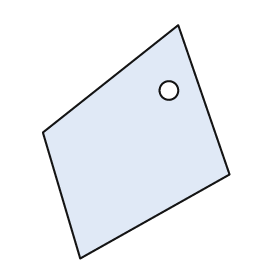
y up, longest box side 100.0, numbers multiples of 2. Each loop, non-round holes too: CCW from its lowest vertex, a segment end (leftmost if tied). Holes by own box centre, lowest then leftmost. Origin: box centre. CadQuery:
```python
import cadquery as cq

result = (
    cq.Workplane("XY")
    .moveTo(-24.0, -50.0)
    .lineTo(40.0, -14.0)
    .lineTo(18.0, 50.0)
    .lineTo(-40.0, 4.0)
    .close()
    .moveTo(14.0, 22.0)
    .circle(4.0)
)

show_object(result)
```